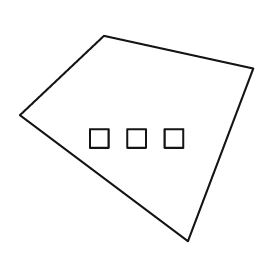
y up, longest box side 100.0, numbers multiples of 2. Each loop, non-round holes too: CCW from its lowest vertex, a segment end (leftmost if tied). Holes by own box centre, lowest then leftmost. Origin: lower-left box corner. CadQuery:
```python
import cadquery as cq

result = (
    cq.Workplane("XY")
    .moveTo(72.0, 0.0)
    .lineTo(100.0, 74.0)
    .lineTo(36.0, 88.0)
    .lineTo(0.0, 54.0)
    .close()
    .moveTo(30.0, 40.0)
    .lineTo(38.0, 40.0)
    .lineTo(38.0, 48.0)
    .lineTo(30.0, 48.0)
    .close()
    .moveTo(46.0, 40.0)
    .lineTo(54.0, 40.0)
    .lineTo(54.0, 48.0)
    .lineTo(46.0, 48.0)
    .close()
    .moveTo(62.0, 40.0)
    .lineTo(70.0, 40.0)
    .lineTo(70.0, 48.0)
    .lineTo(62.0, 48.0)
    .close()
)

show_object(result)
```